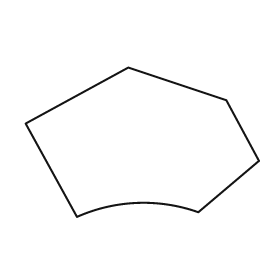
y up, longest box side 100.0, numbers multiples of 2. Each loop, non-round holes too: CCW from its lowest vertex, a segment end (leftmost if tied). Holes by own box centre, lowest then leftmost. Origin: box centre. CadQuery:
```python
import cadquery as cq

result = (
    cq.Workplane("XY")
    .moveTo(-28.0, -32.0)
    .threePointArc((-2.0, -26.0), (24.0, -30.0))
    .lineTo(50.0, -8.0)
    .lineTo(36.0, 18.0)
    .lineTo(-6.0, 32.0)
    .lineTo(-50.0, 8.0)
    .close()
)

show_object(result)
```